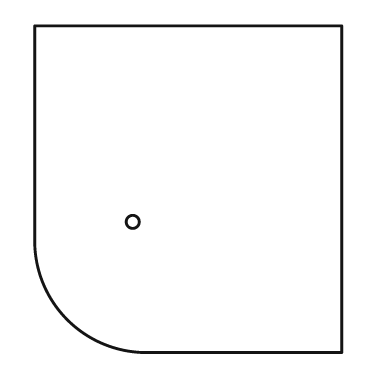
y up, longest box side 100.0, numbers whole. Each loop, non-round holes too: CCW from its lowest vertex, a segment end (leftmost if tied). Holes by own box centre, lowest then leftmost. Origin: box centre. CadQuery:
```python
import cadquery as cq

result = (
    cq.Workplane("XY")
    .moveTo(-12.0, -50.0)
    .lineTo(47.0, -50.0)
    .lineTo(47.0, 50.0)
    .lineTo(-47.0, 50.0)
    .lineTo(-47.0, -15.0)
    .threePointArc((-37.0, -40.0), (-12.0, -50.0))
    .close()
    .moveTo(-17.0, -10.0)
    .circle(2.0)
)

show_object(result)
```